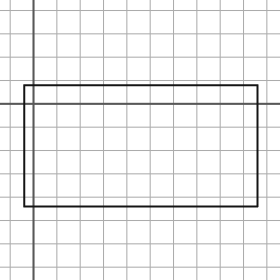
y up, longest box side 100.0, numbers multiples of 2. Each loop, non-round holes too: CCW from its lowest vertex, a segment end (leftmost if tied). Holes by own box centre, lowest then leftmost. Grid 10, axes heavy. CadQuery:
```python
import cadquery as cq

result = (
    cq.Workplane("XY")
    .moveTo(-4.0, -44.0)
    .lineTo(96.0, -44.0)
    .lineTo(96.0, 8.0)
    .lineTo(-4.0, 8.0)
    .close()
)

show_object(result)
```